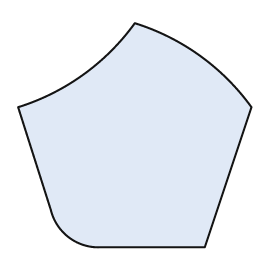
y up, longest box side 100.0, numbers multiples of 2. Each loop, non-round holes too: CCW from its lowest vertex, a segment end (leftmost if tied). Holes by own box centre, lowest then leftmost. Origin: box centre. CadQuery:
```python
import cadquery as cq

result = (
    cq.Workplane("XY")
    .moveTo(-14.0, -48.0)
    .lineTo(30.0, -48.0)
    .lineTo(50.0, 12.0)
    .threePointArc((28.0, 34.0), (0.0, 48.0))
    .threePointArc((-22.0, 26.0), (-50.0, 12.0))
    .lineTo(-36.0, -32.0)
    .threePointArc((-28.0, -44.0), (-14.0, -48.0))
    .close()
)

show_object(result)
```